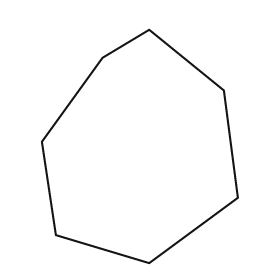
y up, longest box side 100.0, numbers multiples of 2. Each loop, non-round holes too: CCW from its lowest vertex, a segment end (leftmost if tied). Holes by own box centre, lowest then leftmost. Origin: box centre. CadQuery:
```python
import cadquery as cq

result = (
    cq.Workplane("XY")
    .moveTo(4.0, -50.0)
    .lineTo(42.0, -22.0)
    .lineTo(36.0, 24.0)
    .lineTo(4.0, 50.0)
    .lineTo(-16.0, 38.0)
    .lineTo(-42.0, 2.0)
    .lineTo(-36.0, -38.0)
    .close()
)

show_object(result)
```